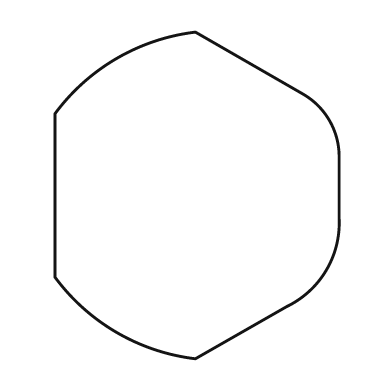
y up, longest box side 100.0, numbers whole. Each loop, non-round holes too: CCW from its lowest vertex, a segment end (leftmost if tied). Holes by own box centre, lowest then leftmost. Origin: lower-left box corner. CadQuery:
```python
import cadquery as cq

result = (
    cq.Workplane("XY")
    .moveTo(43.0, 0.0)
    .lineTo(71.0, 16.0)
    .threePointArc((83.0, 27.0), (87.0, 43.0))
    .lineTo(87.0, 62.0)
    .threePointArc((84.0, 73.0), (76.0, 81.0))
    .lineTo(43.0, 100.0)
    .threePointArc((19.0, 92.0), (0.0, 75.0))
    .lineTo(0.0, 25.0)
    .threePointArc((19.0, 8.0), (43.0, 0.0))
    .close()
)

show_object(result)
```